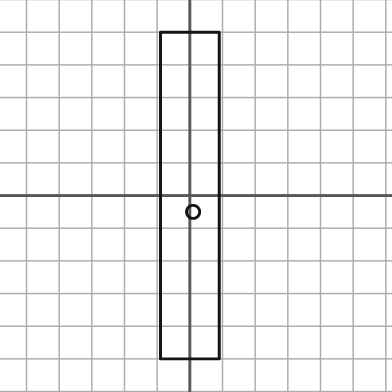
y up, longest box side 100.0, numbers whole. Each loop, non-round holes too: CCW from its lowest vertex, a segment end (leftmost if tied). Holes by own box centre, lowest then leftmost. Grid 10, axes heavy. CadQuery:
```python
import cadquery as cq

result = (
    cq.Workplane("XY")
    .moveTo(-9.0, -50.0)
    .lineTo(9.0, -50.0)
    .lineTo(9.0, 50.0)
    .lineTo(-9.0, 50.0)
    .close()
    .moveTo(1.0, -5.0)
    .circle(2.0)
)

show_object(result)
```